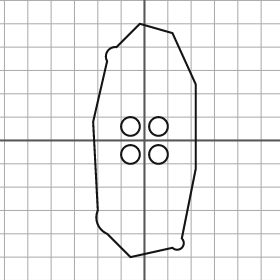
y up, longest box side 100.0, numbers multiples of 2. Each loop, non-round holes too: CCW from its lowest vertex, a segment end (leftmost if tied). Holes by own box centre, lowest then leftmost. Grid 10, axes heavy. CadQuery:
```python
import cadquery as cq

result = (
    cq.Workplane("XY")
    .moveTo(-6.0, -50.0)
    .lineTo(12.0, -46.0)
    .threePointArc((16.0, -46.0), (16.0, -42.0))
    .lineTo(22.0, -12.0)
    .lineTo(22.0, 24.0)
    .lineTo(12.0, 46.0)
    .lineTo(-2.0, 50.0)
    .lineTo(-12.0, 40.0)
    .threePointArc((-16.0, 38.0), (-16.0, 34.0))
    .lineTo(-22.0, 8.0)
    .lineTo(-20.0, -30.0)
    .threePointArc((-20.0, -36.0), (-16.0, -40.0))
    .close()
    .moveTo(-6.0, -6.0)
    .circle(4.0)
    .moveTo(6.0, -6.0)
    .circle(4.0)
    .moveTo(-6.0, 6.0)
    .circle(4.0)
    .moveTo(6.0, 6.0)
    .circle(4.0)
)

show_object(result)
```